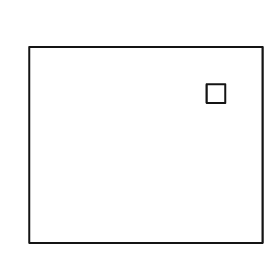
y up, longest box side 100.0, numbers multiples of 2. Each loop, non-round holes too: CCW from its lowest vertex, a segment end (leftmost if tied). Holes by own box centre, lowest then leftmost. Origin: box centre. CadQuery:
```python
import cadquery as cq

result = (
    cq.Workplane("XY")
    .moveTo(-50.0, -42.0)
    .lineTo(50.0, -42.0)
    .lineTo(50.0, 42.0)
    .lineTo(-50.0, 42.0)
    .close()
    .moveTo(26.0, 18.0)
    .lineTo(34.0, 18.0)
    .lineTo(34.0, 26.0)
    .lineTo(26.0, 26.0)
    .close()
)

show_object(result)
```